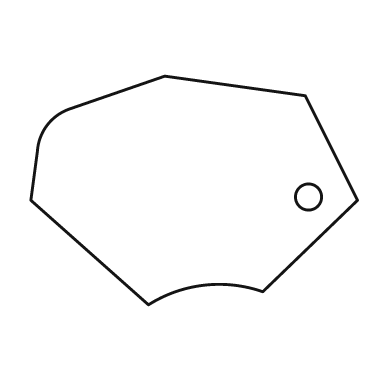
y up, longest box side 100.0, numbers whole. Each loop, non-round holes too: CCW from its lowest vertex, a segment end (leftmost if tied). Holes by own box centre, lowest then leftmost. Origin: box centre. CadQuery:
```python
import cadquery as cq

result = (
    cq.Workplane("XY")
    .moveTo(-14.0, -35.0)
    .threePointArc((3.0, -29.0), (21.0, -31.0))
    .lineTo(50.0, -3.0)
    .lineTo(34.0, 29.0)
    .lineTo(-9.0, 35.0)
    .lineTo(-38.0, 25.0)
    .threePointArc((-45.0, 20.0), (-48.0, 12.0))
    .lineTo(-50.0, -3.0)
    .close()
    .moveTo(35.0, -2.0)
    .circle(4.0)
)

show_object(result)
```